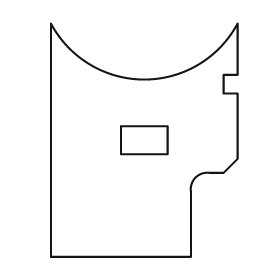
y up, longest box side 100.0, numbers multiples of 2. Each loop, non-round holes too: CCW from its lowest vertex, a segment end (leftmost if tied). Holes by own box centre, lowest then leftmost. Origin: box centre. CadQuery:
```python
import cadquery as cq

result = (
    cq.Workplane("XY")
    .moveTo(-40.0, -50.0)
    .lineTo(20.0, -50.0)
    .lineTo(20.0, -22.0)
    .threePointArc((22.0, -16.0), (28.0, -14.0))
    .lineTo(34.0, -14.0)
    .lineTo(40.0, -8.0)
    .lineTo(40.0, 20.0)
    .lineTo(34.0, 20.0)
    .lineTo(34.0, 28.0)
    .lineTo(40.0, 28.0)
    .lineTo(40.0, 50.0)
    .threePointArc((0.0, 26.0), (-40.0, 50.0))
    .close()
    .moveTo(-10.0, -6.0)
    .lineTo(10.0, -6.0)
    .lineTo(10.0, 6.0)
    .lineTo(-10.0, 6.0)
    .close()
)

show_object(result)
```